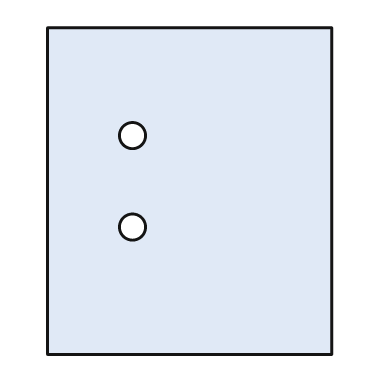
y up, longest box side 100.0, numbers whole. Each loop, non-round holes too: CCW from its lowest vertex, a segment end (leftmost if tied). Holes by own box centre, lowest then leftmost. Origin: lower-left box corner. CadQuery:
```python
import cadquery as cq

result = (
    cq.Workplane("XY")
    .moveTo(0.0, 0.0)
    .lineTo(87.0, 0.0)
    .lineTo(87.0, 100.0)
    .lineTo(0.0, 100.0)
    .close()
    .moveTo(26.0, 39.0)
    .circle(4.0)
    .moveTo(26.0, 67.0)
    .circle(4.0)
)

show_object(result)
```